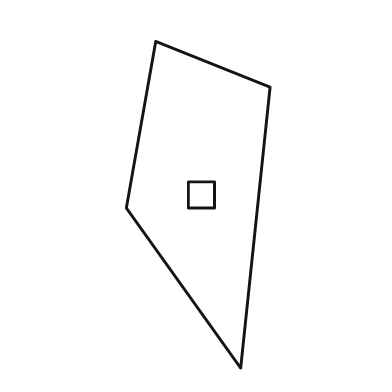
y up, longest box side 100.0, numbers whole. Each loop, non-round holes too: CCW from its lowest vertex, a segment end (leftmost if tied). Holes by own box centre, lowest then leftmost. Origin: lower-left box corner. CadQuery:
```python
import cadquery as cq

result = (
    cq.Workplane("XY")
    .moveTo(35.0, 0.0)
    .lineTo(44.0, 86.0)
    .lineTo(9.0, 100.0)
    .lineTo(0.0, 49.0)
    .close()
    .moveTo(19.0, 49.0)
    .lineTo(27.0, 49.0)
    .lineTo(27.0, 57.0)
    .lineTo(19.0, 57.0)
    .close()
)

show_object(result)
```